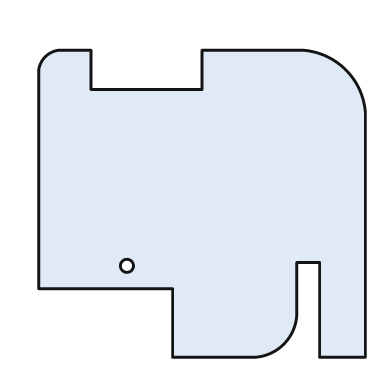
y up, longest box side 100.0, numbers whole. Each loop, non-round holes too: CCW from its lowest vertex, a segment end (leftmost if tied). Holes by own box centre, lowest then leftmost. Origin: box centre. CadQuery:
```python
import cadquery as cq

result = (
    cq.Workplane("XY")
    .moveTo(-9.0, -47.0)
    .lineTo(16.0, -47.0)
    .threePointArc((25.0, -43.0), (29.0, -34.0))
    .lineTo(29.0, -18.0)
    .lineTo(36.0, -18.0)
    .lineTo(36.0, -47.0)
    .lineTo(50.0, -47.0)
    .lineTo(50.0, 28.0)
    .threePointArc((44.0, 41.0), (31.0, 47.0))
    .lineTo(0.0, 47.0)
    .lineTo(0.0, 35.0)
    .lineTo(-34.0, 35.0)
    .lineTo(-34.0, 47.0)
    .lineTo(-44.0, 47.0)
    .threePointArc((-48.0, 45.0), (-50.0, 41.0))
    .lineTo(-50.0, -26.0)
    .lineTo(-9.0, -26.0)
    .close()
    .moveTo(-23.0, -19.0)
    .circle(2.0)
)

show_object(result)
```